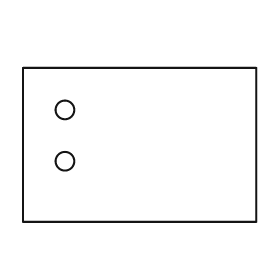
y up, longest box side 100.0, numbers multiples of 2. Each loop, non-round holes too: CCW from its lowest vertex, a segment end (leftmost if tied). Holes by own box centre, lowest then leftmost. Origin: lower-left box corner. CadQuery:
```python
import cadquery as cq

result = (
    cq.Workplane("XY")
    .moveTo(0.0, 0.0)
    .lineTo(100.0, 0.0)
    .lineTo(100.0, 66.0)
    .lineTo(0.0, 66.0)
    .close()
    .moveTo(18.0, 26.0)
    .circle(4.0)
    .moveTo(18.0, 48.0)
    .circle(4.0)
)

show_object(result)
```